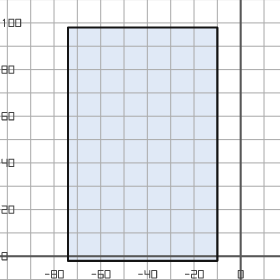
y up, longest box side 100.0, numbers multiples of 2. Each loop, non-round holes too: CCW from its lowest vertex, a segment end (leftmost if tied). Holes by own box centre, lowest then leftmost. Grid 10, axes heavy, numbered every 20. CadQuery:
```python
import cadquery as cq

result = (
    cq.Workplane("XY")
    .moveTo(-74.0, -2.0)
    .lineTo(-10.0, -2.0)
    .lineTo(-10.0, 98.0)
    .lineTo(-74.0, 98.0)
    .close()
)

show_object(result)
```